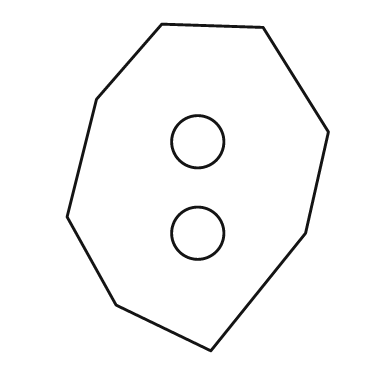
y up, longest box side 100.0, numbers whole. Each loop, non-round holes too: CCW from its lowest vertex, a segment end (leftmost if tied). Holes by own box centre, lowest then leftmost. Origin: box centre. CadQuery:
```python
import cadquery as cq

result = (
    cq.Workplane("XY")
    .moveTo(4.0, -50.0)
    .lineTo(33.0, -14.0)
    .lineTo(40.0, 17.0)
    .lineTo(20.0, 49.0)
    .lineTo(-11.0, 50.0)
    .lineTo(-31.0, 27.0)
    .lineTo(-40.0, -9.0)
    .lineTo(-25.0, -36.0)
    .close()
    .moveTo(0.0, -14.0)
    .circle(8.0)
    .moveTo(0.0, 14.0)
    .circle(8.0)
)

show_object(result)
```